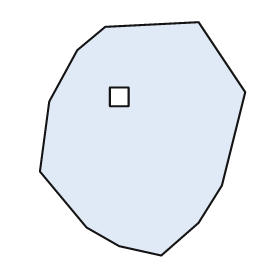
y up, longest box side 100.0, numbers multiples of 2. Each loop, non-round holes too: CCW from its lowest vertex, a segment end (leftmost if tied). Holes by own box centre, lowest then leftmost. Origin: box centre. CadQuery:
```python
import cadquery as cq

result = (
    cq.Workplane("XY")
    .moveTo(8.0, -50.0)
    .lineTo(24.0, -36.0)
    .lineTo(34.0, -20.0)
    .lineTo(44.0, 20.0)
    .lineTo(24.0, 50.0)
    .lineTo(-16.0, 48.0)
    .lineTo(-28.0, 38.0)
    .lineTo(-40.0, 16.0)
    .lineTo(-44.0, -14.0)
    .lineTo(-24.0, -38.0)
    .lineTo(-10.0, -46.0)
    .close()
    .moveTo(-14.0, 14.0)
    .lineTo(-6.0, 14.0)
    .lineTo(-6.0, 22.0)
    .lineTo(-14.0, 22.0)
    .close()
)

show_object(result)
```